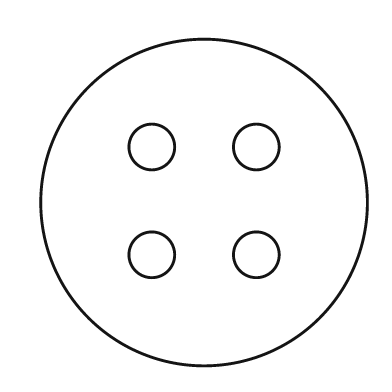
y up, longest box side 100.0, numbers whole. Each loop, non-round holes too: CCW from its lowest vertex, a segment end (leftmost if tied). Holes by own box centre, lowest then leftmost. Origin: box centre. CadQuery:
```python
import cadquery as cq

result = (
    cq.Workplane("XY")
    .moveTo(0.0, 0.0)
    .circle(50.0)
    .moveTo(-16.0, -16.0)
    .circle(7.0)
    .moveTo(16.0, -16.0)
    .circle(7.0)
    .moveTo(-16.0, 17.0)
    .circle(7.0)
    .moveTo(16.0, 17.0)
    .circle(7.0)
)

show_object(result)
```